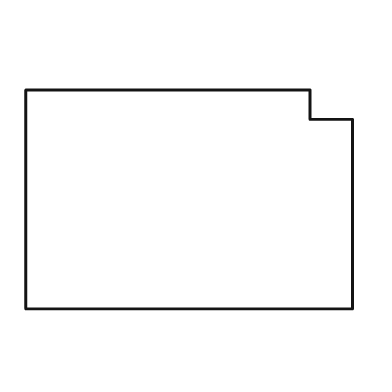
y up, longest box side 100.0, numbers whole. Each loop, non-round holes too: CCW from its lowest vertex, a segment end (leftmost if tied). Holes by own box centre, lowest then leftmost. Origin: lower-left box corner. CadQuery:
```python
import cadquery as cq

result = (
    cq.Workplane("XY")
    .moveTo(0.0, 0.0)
    .lineTo(100.0, 0.0)
    .lineTo(100.0, 58.0)
    .lineTo(87.0, 58.0)
    .lineTo(87.0, 67.0)
    .lineTo(0.0, 67.0)
    .close()
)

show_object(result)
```